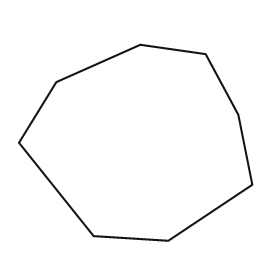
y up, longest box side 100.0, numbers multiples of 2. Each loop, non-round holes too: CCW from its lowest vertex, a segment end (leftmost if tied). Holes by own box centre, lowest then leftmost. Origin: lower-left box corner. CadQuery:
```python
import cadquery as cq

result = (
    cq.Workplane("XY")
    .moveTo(64.0, 0.0)
    .lineTo(100.0, 24.0)
    .lineTo(94.0, 54.0)
    .lineTo(80.0, 80.0)
    .lineTo(52.0, 84.0)
    .lineTo(16.0, 68.0)
    .lineTo(0.0, 42.0)
    .lineTo(32.0, 2.0)
    .close()
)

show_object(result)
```